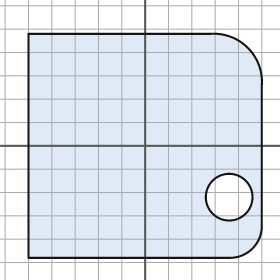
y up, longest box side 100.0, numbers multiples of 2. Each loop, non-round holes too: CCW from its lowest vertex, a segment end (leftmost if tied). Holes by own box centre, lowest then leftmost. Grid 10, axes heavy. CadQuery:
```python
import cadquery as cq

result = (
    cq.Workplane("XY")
    .moveTo(-50.0, -48.0)
    .lineTo(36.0, -48.0)
    .threePointArc((46.0, -44.0), (50.0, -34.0))
    .lineTo(50.0, 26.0)
    .threePointArc((44.0, 42.0), (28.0, 48.0))
    .lineTo(-50.0, 48.0)
    .close()
    .moveTo(36.0, -22.0)
    .circle(10.0)
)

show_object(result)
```